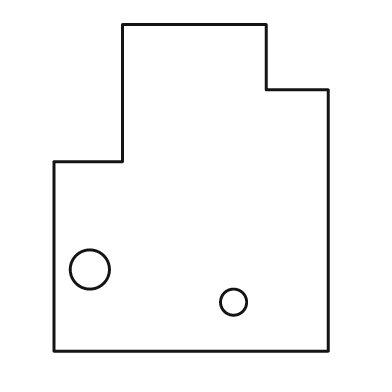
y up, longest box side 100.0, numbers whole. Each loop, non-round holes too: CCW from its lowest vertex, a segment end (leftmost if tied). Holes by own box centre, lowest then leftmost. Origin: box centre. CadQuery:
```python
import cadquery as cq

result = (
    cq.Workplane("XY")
    .moveTo(-42.0, -50.0)
    .lineTo(42.0, -50.0)
    .lineTo(42.0, 30.0)
    .lineTo(23.0, 30.0)
    .lineTo(23.0, 50.0)
    .lineTo(-21.0, 50.0)
    .lineTo(-21.0, 8.0)
    .lineTo(-42.0, 8.0)
    .close()
    .moveTo(13.0, -35.0)
    .circle(4.0)
    .moveTo(-31.0, -25.0)
    .circle(6.0)
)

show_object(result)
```